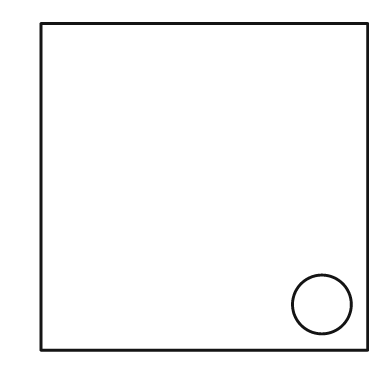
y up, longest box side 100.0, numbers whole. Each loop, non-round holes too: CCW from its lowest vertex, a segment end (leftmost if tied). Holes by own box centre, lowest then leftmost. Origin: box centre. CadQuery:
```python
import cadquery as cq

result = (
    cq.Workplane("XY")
    .moveTo(-50.0, -50.0)
    .lineTo(50.0, -50.0)
    .lineTo(50.0, 50.0)
    .lineTo(-50.0, 50.0)
    .close()
    .moveTo(36.0, -36.0)
    .circle(9.0)
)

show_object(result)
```